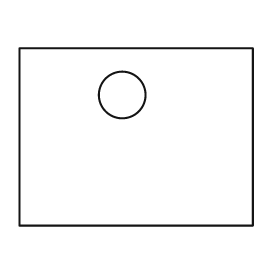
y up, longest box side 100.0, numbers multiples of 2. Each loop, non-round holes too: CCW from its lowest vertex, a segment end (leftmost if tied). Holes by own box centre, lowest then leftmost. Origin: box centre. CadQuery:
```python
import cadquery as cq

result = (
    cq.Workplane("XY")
    .moveTo(-50.0, -38.0)
    .lineTo(50.0, -38.0)
    .lineTo(50.0, 38.0)
    .lineTo(-50.0, 38.0)
    .close()
    .moveTo(-6.0, 18.0)
    .circle(10.0)
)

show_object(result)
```